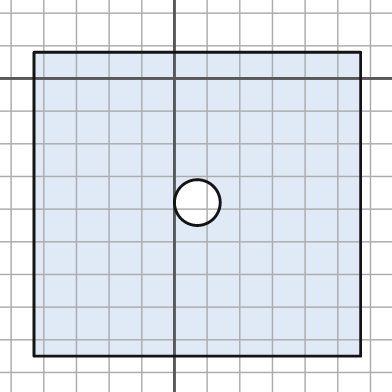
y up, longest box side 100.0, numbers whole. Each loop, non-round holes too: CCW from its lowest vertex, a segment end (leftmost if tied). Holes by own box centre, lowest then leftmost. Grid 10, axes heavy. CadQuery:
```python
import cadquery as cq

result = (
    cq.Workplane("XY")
    .moveTo(-43.0, -85.0)
    .lineTo(57.0, -85.0)
    .lineTo(57.0, 8.0)
    .lineTo(-43.0, 8.0)
    .close()
    .moveTo(7.0, -38.0)
    .circle(7.0)
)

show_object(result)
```